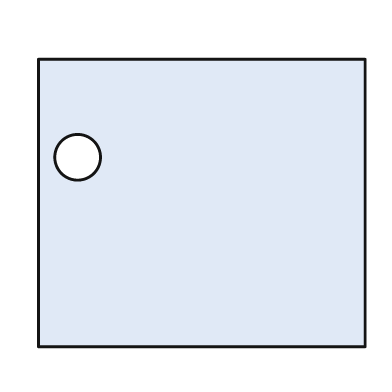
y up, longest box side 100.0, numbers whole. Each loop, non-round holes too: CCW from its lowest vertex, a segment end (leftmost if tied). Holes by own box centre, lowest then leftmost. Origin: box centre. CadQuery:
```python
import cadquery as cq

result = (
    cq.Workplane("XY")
    .moveTo(-50.0, -44.0)
    .lineTo(50.0, -44.0)
    .lineTo(50.0, 44.0)
    .lineTo(-50.0, 44.0)
    .close()
    .moveTo(-38.0, 14.0)
    .circle(7.0)
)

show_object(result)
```